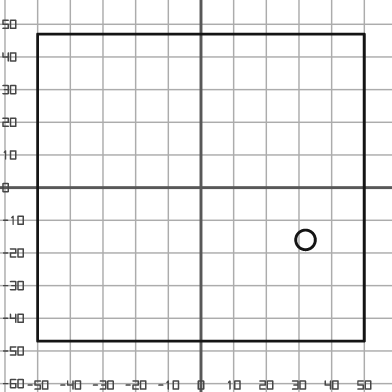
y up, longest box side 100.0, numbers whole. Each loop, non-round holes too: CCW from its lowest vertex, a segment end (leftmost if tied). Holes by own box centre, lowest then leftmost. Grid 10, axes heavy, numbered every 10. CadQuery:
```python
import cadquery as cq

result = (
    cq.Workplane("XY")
    .moveTo(-50.0, -47.0)
    .lineTo(50.0, -47.0)
    .lineTo(50.0, 47.0)
    .lineTo(-50.0, 47.0)
    .close()
    .moveTo(32.0, -16.0)
    .circle(3.0)
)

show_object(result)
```